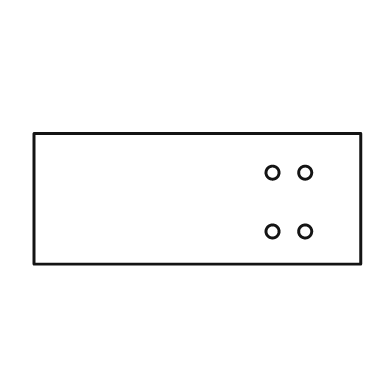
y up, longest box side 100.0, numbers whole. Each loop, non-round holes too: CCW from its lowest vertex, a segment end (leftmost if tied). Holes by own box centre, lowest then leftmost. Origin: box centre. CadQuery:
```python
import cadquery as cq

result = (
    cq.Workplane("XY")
    .moveTo(-50.0, -20.0)
    .lineTo(50.0, -20.0)
    .lineTo(50.0, 20.0)
    .lineTo(-50.0, 20.0)
    .close()
    .moveTo(23.0, -10.0)
    .circle(2.0)
    .moveTo(33.0, -10.0)
    .circle(2.0)
    .moveTo(23.0, 8.0)
    .circle(2.0)
    .moveTo(33.0, 8.0)
    .circle(2.0)
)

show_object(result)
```